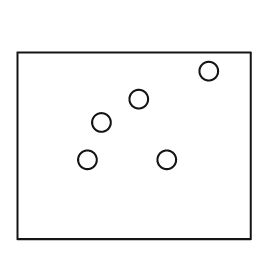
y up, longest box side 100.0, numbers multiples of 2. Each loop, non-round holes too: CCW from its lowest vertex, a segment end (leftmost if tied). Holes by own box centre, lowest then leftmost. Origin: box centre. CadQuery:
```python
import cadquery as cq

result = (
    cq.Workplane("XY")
    .moveTo(-50.0, -40.0)
    .lineTo(50.0, -40.0)
    .lineTo(50.0, 40.0)
    .lineTo(-50.0, 40.0)
    .close()
    .moveTo(-20.0, -6.0)
    .circle(4.0)
    .moveTo(14.0, -6.0)
    .circle(4.0)
    .moveTo(-14.0, 10.0)
    .circle(4.0)
    .moveTo(2.0, 20.0)
    .circle(4.0)
    .moveTo(32.0, 32.0)
    .circle(4.0)
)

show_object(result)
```